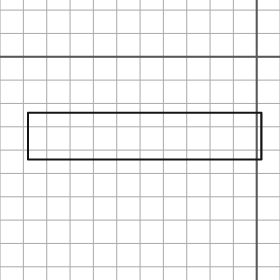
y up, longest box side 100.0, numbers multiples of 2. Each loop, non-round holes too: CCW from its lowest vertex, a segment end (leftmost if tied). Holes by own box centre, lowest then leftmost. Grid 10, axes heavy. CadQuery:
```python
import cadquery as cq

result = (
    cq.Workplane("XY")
    .moveTo(-98.0, -44.0)
    .lineTo(2.0, -44.0)
    .lineTo(2.0, -24.0)
    .lineTo(-98.0, -24.0)
    .close()
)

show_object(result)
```